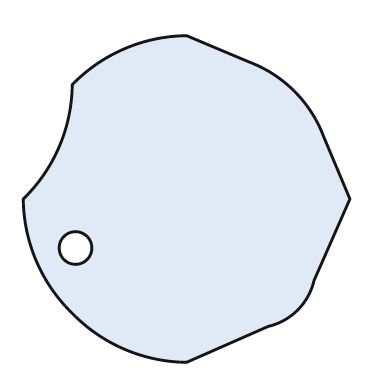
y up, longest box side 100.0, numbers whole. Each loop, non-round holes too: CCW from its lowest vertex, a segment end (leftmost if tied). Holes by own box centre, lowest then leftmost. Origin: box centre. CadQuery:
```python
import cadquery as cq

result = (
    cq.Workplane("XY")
    .moveTo(0.0, -50.0)
    .lineTo(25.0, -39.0)
    .threePointArc((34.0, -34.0), (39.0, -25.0))
    .lineTo(50.0, 0.0)
    .lineTo(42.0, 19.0)
    .threePointArc((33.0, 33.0), (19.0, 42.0))
    .lineTo(0.0, 50.0)
    .threePointArc((-19.0, 46.0), (-35.0, 35.0))
    .threePointArc((-39.0, 16.0), (-50.0, 0.0))
    .threePointArc((-46.0, -19.0), (-35.0, -35.0))
    .threePointArc((-19.0, -46.0), (0.0, -50.0))
    .close()
    .moveTo(-34.0, -15.0)
    .circle(5.0)
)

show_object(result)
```